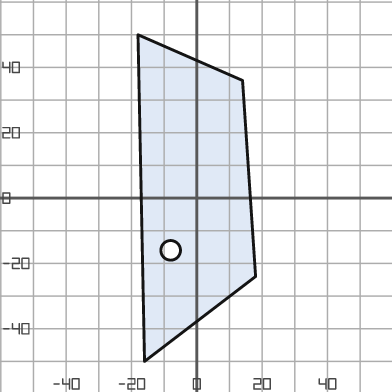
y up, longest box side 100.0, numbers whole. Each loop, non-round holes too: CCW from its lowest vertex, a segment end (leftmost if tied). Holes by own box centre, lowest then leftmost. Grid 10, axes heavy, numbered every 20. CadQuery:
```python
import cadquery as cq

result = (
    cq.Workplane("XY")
    .moveTo(-16.0, -50.0)
    .lineTo(18.0, -24.0)
    .lineTo(14.0, 36.0)
    .lineTo(-18.0, 50.0)
    .close()
    .moveTo(-8.0, -16.0)
    .circle(3.0)
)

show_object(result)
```